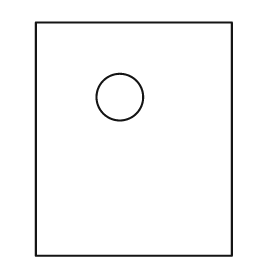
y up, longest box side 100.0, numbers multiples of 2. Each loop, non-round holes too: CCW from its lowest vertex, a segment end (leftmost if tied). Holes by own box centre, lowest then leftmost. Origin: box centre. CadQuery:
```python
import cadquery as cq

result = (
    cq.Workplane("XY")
    .moveTo(-42.0, -50.0)
    .lineTo(42.0, -50.0)
    .lineTo(42.0, 50.0)
    .lineTo(-42.0, 50.0)
    .close()
    .moveTo(-6.0, 18.0)
    .circle(10.0)
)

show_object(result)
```